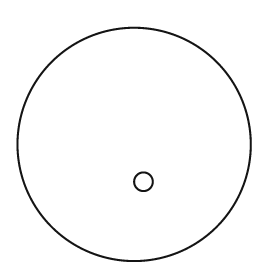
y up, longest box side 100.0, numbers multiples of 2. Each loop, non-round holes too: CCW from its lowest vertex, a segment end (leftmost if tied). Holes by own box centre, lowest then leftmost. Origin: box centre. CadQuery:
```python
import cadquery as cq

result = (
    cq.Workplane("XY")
    .moveTo(0.0, 0.0)
    .circle(50.0)
    .moveTo(4.0, -16.0)
    .circle(4.0)
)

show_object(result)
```